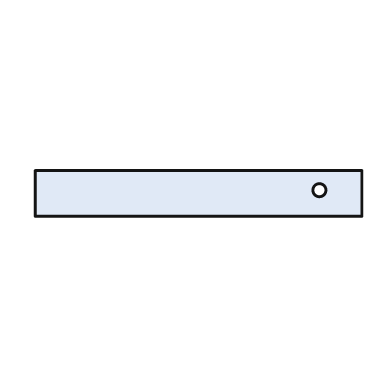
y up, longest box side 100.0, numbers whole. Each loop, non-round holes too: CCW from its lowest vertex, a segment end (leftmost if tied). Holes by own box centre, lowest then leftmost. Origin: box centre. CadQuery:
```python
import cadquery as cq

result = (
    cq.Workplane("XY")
    .moveTo(-50.0, -7.0)
    .lineTo(50.0, -7.0)
    .lineTo(50.0, 7.0)
    .lineTo(-50.0, 7.0)
    .close()
    .moveTo(37.0, 1.0)
    .circle(2.0)
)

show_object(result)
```